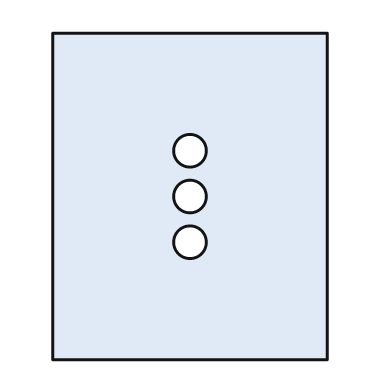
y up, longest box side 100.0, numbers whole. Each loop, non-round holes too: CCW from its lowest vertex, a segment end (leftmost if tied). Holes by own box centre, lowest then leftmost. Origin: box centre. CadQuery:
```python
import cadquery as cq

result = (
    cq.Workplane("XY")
    .moveTo(-42.0, -50.0)
    .lineTo(42.0, -50.0)
    .lineTo(42.0, 50.0)
    .lineTo(-42.0, 50.0)
    .close()
    .moveTo(0.0, -14.0)
    .circle(5.0)
    .moveTo(0.0, 0.0)
    .circle(5.0)
    .moveTo(0.0, 14.0)
    .circle(5.0)
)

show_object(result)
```